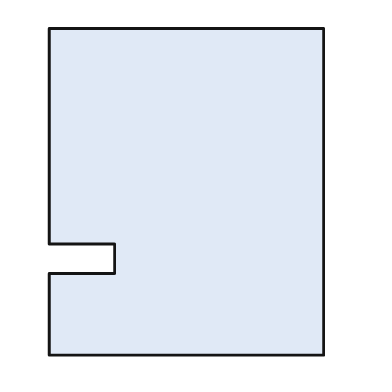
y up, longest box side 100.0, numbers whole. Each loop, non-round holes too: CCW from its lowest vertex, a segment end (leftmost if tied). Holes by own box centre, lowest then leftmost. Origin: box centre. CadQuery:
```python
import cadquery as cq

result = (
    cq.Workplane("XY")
    .moveTo(-42.0, -50.0)
    .lineTo(42.0, -50.0)
    .lineTo(42.0, 50.0)
    .lineTo(-42.0, 50.0)
    .lineTo(-42.0, -16.0)
    .lineTo(-22.0, -16.0)
    .lineTo(-22.0, -25.0)
    .lineTo(-42.0, -25.0)
    .close()
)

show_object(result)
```